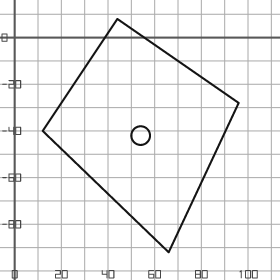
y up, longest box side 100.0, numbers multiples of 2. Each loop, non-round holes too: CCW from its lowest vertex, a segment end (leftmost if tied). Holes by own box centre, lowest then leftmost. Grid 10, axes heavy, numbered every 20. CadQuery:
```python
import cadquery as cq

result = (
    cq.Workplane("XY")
    .moveTo(66.0, -92.0)
    .lineTo(96.0, -28.0)
    .lineTo(44.0, 8.0)
    .lineTo(12.0, -40.0)
    .close()
    .moveTo(54.0, -42.0)
    .circle(4.0)
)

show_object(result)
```